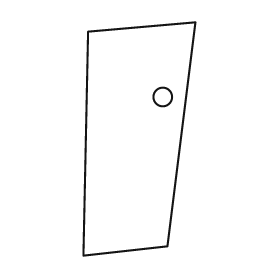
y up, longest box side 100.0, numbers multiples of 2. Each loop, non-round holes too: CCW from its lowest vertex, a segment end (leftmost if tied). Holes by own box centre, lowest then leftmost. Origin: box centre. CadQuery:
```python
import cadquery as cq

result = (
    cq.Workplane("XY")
    .moveTo(-24.0, -50.0)
    .lineTo(12.0, -46.0)
    .lineTo(24.0, 50.0)
    .lineTo(-22.0, 46.0)
    .close()
    .moveTo(10.0, 18.0)
    .circle(4.0)
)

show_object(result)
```